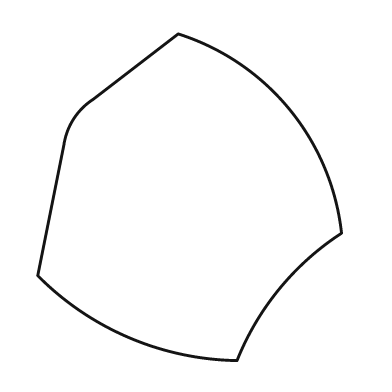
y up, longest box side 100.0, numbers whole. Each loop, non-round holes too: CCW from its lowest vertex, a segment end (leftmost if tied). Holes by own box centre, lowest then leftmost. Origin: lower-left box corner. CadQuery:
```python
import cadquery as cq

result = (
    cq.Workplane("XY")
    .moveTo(61.0, 0.0)
    .threePointArc((74.0, 22.0), (93.0, 39.0))
    .threePointArc((77.0, 77.0), (43.0, 100.0))
    .lineTo(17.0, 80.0)
    .threePointArc((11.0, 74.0), (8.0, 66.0))
    .lineTo(0.0, 26.0)
    .threePointArc((28.0, 7.0), (61.0, 0.0))
    .close()
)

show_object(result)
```